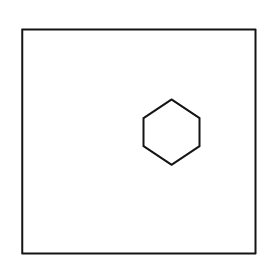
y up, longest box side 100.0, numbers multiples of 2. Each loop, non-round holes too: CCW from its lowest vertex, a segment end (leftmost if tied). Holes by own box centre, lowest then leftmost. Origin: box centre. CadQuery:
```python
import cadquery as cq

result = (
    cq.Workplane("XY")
    .moveTo(-50.0, -48.0)
    .lineTo(50.0, -48.0)
    .lineTo(50.0, 48.0)
    .lineTo(-50.0, 48.0)
    .close()
    .moveTo(14.0, -10.0)
    .lineTo(26.0, -2.0)
    .lineTo(26.0, 10.0)
    .lineTo(14.0, 18.0)
    .lineTo(2.0, 10.0)
    .lineTo(2.0, -2.0)
    .close()
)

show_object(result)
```